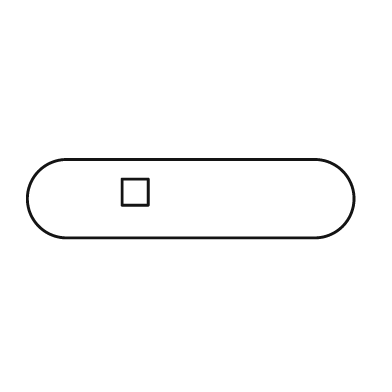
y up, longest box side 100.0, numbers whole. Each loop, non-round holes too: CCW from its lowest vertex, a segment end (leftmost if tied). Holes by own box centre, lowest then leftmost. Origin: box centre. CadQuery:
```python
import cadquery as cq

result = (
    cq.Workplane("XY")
    .moveTo(-38.0, -12.0)
    .lineTo(38.0, -12.0)
    .threePointArc((50.0, 0.0), (38.0, 12.0))
    .lineTo(-38.0, 12.0)
    .threePointArc((-50.0, 0.0), (-38.0, -12.0))
    .close()
    .moveTo(-21.0, -2.0)
    .lineTo(-13.0, -2.0)
    .lineTo(-13.0, 6.0)
    .lineTo(-21.0, 6.0)
    .close()
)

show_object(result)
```